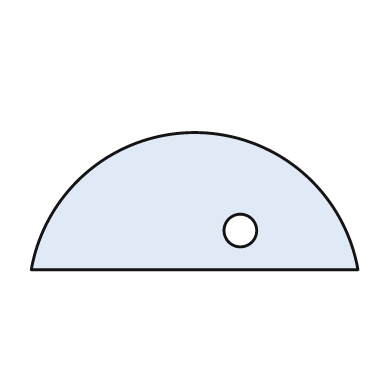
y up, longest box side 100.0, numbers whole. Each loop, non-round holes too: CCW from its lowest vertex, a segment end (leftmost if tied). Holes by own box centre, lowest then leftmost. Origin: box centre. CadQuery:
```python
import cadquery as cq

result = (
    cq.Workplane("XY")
    .moveTo(-50.0, -21.0)
    .lineTo(50.0, -21.0)
    .threePointArc((0.0, 21.0), (-50.0, -21.0))
    .close()
    .moveTo(14.0, -9.0)
    .circle(5.0)
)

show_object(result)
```